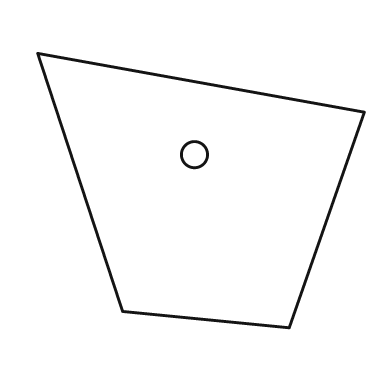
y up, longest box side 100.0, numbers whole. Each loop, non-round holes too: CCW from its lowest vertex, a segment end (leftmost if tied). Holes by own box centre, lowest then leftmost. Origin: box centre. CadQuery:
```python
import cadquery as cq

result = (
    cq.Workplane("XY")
    .moveTo(27.0, -42.0)
    .lineTo(50.0, 24.0)
    .lineTo(-50.0, 42.0)
    .lineTo(-24.0, -37.0)
    .close()
    .moveTo(-2.0, 11.0)
    .circle(4.0)
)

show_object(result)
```